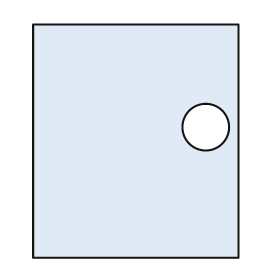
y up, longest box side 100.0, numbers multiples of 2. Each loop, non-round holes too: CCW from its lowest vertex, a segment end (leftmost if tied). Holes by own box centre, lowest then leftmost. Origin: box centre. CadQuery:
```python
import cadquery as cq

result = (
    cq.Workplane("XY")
    .moveTo(-44.0, -50.0)
    .lineTo(44.0, -50.0)
    .lineTo(44.0, 50.0)
    .lineTo(-44.0, 50.0)
    .close()
    .moveTo(30.0, 6.0)
    .circle(10.0)
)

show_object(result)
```